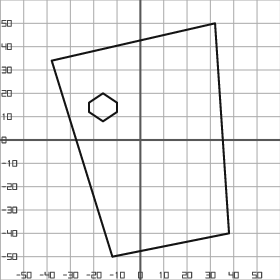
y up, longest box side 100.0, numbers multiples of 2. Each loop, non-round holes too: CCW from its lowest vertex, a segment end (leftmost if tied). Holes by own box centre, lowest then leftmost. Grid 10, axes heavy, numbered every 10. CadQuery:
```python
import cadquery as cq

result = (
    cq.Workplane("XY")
    .moveTo(-12.0, -50.0)
    .lineTo(38.0, -40.0)
    .lineTo(32.0, 50.0)
    .lineTo(-38.0, 34.0)
    .close()
    .moveTo(-16.0, 8.0)
    .lineTo(-10.0, 12.0)
    .lineTo(-10.0, 16.0)
    .lineTo(-16.0, 20.0)
    .lineTo(-22.0, 16.0)
    .lineTo(-22.0, 12.0)
    .close()
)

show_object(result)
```